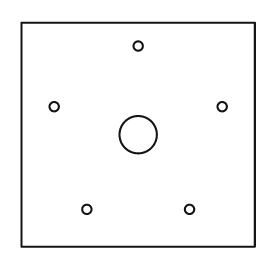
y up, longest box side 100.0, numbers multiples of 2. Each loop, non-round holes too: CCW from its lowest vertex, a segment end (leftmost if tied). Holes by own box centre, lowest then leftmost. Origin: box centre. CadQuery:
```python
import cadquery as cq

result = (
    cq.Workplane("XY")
    .moveTo(-50.0, -48.0)
    .lineTo(50.0, -48.0)
    .lineTo(50.0, 48.0)
    .lineTo(-50.0, 48.0)
    .close()
    .moveTo(-22.0, -32.0)
    .circle(2.0)
    .moveTo(22.0, -32.0)
    .circle(2.0)
    .moveTo(0.0, 0.0)
    .circle(8.0)
    .moveTo(-36.0, 12.0)
    .circle(2.0)
    .moveTo(36.0, 12.0)
    .circle(2.0)
    .moveTo(0.0, 38.0)
    .circle(2.0)
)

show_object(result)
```